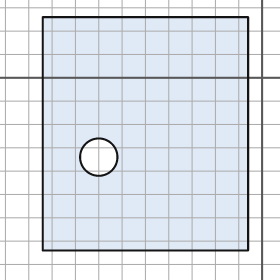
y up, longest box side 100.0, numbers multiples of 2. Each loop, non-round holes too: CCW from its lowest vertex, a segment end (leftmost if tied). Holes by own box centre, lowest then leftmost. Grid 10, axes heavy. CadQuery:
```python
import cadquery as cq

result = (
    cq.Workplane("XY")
    .moveTo(-94.0, -74.0)
    .lineTo(-6.0, -74.0)
    .lineTo(-6.0, 26.0)
    .lineTo(-94.0, 26.0)
    .close()
    .moveTo(-70.0, -34.0)
    .circle(8.0)
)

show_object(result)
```